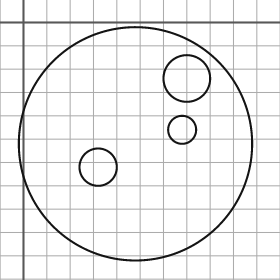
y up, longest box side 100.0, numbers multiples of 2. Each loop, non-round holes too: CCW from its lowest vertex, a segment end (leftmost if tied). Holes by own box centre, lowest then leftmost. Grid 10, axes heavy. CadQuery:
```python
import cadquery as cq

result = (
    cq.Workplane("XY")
    .moveTo(48.0, -52.0)
    .circle(50.0)
    .moveTo(32.0, -62.0)
    .circle(8.0)
    .moveTo(68.0, -46.0)
    .circle(6.0)
    .moveTo(70.0, -24.0)
    .circle(10.0)
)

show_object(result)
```